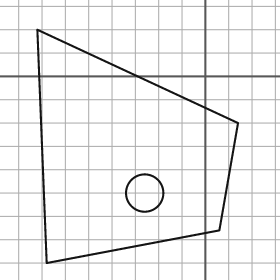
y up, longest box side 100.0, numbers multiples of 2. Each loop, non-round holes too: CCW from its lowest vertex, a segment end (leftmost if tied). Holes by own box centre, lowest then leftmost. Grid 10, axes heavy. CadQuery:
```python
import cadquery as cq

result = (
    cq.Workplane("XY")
    .moveTo(-68.0, -80.0)
    .lineTo(6.0, -66.0)
    .lineTo(14.0, -20.0)
    .lineTo(-72.0, 20.0)
    .close()
    .moveTo(-26.0, -50.0)
    .circle(8.0)
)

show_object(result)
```